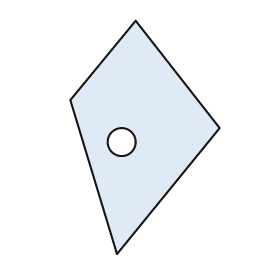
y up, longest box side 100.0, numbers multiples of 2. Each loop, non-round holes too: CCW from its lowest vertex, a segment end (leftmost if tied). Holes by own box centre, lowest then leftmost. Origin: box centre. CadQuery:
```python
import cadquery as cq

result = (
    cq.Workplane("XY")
    .moveTo(-12.0, -50.0)
    .lineTo(32.0, 4.0)
    .lineTo(-4.0, 50.0)
    .lineTo(-32.0, 16.0)
    .close()
    .moveTo(-10.0, -2.0)
    .circle(6.0)
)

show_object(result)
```